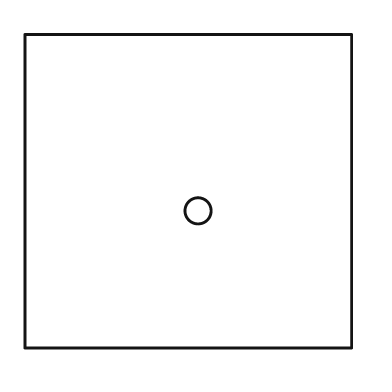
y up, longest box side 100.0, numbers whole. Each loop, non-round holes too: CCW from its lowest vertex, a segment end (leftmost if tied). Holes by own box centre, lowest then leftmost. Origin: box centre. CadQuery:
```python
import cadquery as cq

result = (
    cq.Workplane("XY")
    .moveTo(-50.0, -48.0)
    .lineTo(50.0, -48.0)
    .lineTo(50.0, 48.0)
    .lineTo(-50.0, 48.0)
    .close()
    .moveTo(3.0, -6.0)
    .circle(4.0)
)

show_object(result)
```